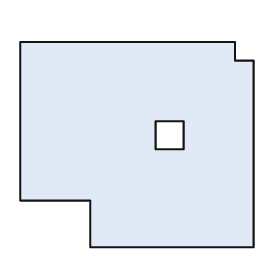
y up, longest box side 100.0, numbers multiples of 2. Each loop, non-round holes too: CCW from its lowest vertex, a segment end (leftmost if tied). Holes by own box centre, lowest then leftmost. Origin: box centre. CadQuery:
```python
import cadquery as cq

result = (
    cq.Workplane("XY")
    .moveTo(-20.0, -44.0)
    .lineTo(50.0, -44.0)
    .lineTo(50.0, 36.0)
    .lineTo(42.0, 36.0)
    .lineTo(42.0, 44.0)
    .lineTo(-50.0, 44.0)
    .lineTo(-50.0, -24.0)
    .lineTo(-20.0, -24.0)
    .close()
    .moveTo(8.0, -2.0)
    .lineTo(20.0, -2.0)
    .lineTo(20.0, 10.0)
    .lineTo(8.0, 10.0)
    .close()
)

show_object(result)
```